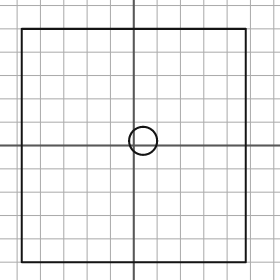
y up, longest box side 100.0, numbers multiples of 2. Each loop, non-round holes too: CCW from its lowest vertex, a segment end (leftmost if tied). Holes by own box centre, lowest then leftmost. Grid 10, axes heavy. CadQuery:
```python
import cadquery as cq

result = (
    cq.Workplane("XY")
    .moveTo(-48.0, -50.0)
    .lineTo(48.0, -50.0)
    .lineTo(48.0, 50.0)
    .lineTo(-48.0, 50.0)
    .close()
    .moveTo(4.0, 2.0)
    .circle(6.0)
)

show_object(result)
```